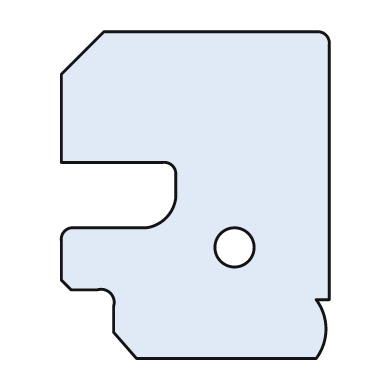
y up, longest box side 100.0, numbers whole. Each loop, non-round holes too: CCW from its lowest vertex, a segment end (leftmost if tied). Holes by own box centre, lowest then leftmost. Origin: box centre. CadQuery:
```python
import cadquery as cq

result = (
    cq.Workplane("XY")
    .moveTo(-18.0, -50.0)
    .lineTo(37.0, -50.0)
    .threePointArc((40.0, -41.0), (37.0, -32.0))
    .lineTo(41.0, -32.0)
    .lineTo(41.0, 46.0)
    .threePointArc((40.0, 49.0), (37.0, 50.0))
    .lineTo(-28.0, 50.0)
    .lineTo(-41.0, 37.0)
    .lineTo(-41.0, 10.0)
    .lineTo(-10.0, 10.0)
    .threePointArc((-7.0, 9.0), (-6.0, 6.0))
    .lineTo(-6.0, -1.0)
    .threePointArc((-9.0, -7.0), (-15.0, -10.0))
    .lineTo(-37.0, -10.0)
    .threePointArc((-40.0, -11.0), (-41.0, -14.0))
    .lineTo(-41.0, -26.0)
    .lineTo(-38.0, -29.0)
    .lineTo(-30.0, -29.0)
    .threePointArc((-26.0, -30.0), (-25.0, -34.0))
    .lineTo(-25.0, -42.0)
    .close()
    .moveTo(12.0, -16.0)
    .circle(6.0)
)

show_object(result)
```